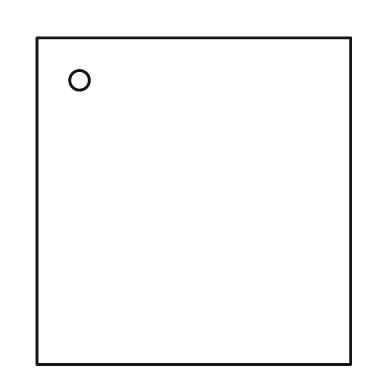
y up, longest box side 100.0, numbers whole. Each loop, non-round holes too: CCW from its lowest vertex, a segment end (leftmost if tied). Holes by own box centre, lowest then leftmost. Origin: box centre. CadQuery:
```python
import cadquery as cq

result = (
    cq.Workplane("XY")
    .moveTo(-48.0, -50.0)
    .lineTo(48.0, -50.0)
    .lineTo(48.0, 50.0)
    .lineTo(-48.0, 50.0)
    .close()
    .moveTo(-35.0, 37.0)
    .circle(3.0)
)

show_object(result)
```